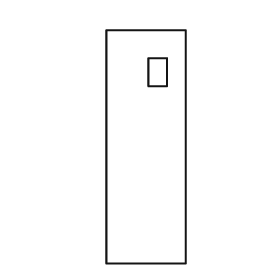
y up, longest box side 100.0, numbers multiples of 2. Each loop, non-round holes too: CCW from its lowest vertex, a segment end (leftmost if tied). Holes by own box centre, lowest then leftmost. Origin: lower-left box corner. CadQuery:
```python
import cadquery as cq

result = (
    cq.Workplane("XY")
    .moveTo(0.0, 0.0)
    .lineTo(34.0, 0.0)
    .lineTo(34.0, 100.0)
    .lineTo(0.0, 100.0)
    .close()
    .moveTo(18.0, 76.0)
    .lineTo(26.0, 76.0)
    .lineTo(26.0, 88.0)
    .lineTo(18.0, 88.0)
    .close()
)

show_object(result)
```